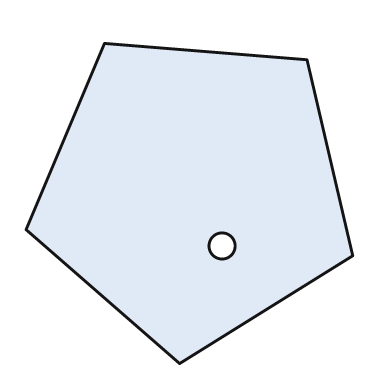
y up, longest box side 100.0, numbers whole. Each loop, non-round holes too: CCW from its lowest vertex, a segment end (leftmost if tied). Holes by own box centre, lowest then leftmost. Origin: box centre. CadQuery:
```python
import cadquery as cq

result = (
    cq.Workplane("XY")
    .moveTo(-3.0, -49.0)
    .lineTo(50.0, -16.0)
    .lineTo(36.0, 44.0)
    .lineTo(-26.0, 49.0)
    .lineTo(-50.0, -8.0)
    .close()
    .moveTo(10.0, -13.0)
    .circle(4.0)
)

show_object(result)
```